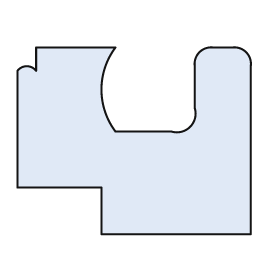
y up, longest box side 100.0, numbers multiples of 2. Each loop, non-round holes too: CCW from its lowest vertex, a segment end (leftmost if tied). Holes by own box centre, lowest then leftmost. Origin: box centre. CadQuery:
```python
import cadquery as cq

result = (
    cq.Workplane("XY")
    .moveTo(-14.0, -40.0)
    .lineTo(50.0, -40.0)
    .lineTo(50.0, 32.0)
    .threePointArc((48.0, 38.0), (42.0, 40.0))
    .lineTo(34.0, 40.0)
    .threePointArc((28.0, 38.0), (26.0, 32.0))
    .lineTo(26.0, 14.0)
    .threePointArc((24.0, 6.0), (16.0, 4.0))
    .lineTo(-8.0, 4.0)
    .threePointArc((-14.0, 22.0), (-8.0, 40.0))
    .lineTo(-42.0, 40.0)
    .lineTo(-42.0, 30.0)
    .threePointArc((-46.0, 32.0), (-50.0, 30.0))
    .lineTo(-50.0, -20.0)
    .lineTo(-14.0, -20.0)
    .close()
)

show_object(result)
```